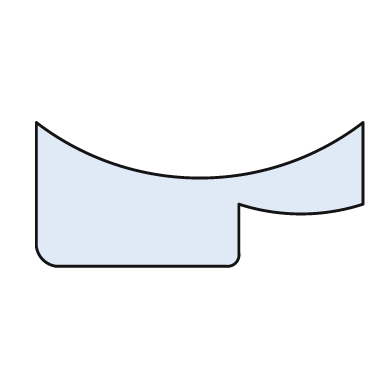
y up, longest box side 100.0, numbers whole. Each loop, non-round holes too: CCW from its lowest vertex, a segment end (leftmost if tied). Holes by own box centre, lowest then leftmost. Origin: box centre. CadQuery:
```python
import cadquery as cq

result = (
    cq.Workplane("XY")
    .moveTo(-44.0, -22.0)
    .lineTo(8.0, -22.0)
    .threePointArc((11.0, -21.0), (12.0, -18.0))
    .lineTo(12.0, -3.0)
    .threePointArc((31.0, -6.0), (50.0, -3.0))
    .lineTo(50.0, 22.0)
    .threePointArc((0.0, 5.0), (-50.0, 22.0))
    .lineTo(-50.0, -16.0)
    .threePointArc((-48.0, -20.0), (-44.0, -22.0))
    .close()
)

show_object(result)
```